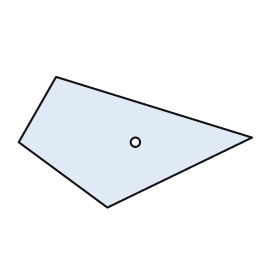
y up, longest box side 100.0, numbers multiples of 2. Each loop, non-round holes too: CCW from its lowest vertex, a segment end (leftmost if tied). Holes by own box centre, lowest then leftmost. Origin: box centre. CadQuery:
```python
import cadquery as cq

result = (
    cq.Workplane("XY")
    .moveTo(-12.0, -28.0)
    .lineTo(50.0, 2.0)
    .lineTo(-34.0, 28.0)
    .lineTo(-50.0, 0.0)
    .close()
    .moveTo(0.0, 0.0)
    .circle(2.0)
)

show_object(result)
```